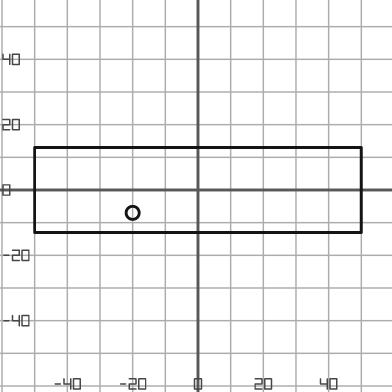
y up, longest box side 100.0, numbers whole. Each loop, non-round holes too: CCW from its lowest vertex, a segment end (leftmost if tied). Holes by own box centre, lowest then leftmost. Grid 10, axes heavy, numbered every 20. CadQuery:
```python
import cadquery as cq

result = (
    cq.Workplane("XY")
    .moveTo(-50.0, -13.0)
    .lineTo(50.0, -13.0)
    .lineTo(50.0, 13.0)
    .lineTo(-50.0, 13.0)
    .close()
    .moveTo(-20.0, -7.0)
    .circle(2.0)
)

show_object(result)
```